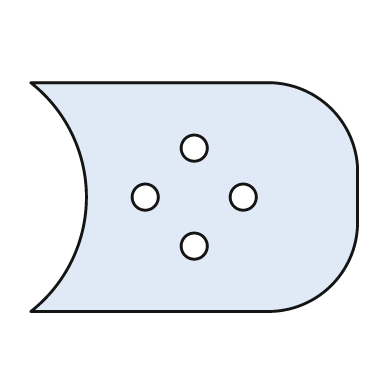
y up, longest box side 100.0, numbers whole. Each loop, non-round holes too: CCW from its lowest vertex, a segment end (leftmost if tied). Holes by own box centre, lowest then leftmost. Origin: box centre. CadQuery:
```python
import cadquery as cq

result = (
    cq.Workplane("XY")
    .moveTo(-50.0, -35.0)
    .lineTo(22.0, -35.0)
    .threePointArc((42.0, -27.0), (50.0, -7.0))
    .lineTo(50.0, 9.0)
    .threePointArc((42.0, 27.0), (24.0, 35.0))
    .lineTo(-50.0, 35.0)
    .threePointArc((-33.0, 0.0), (-50.0, -35.0))
    .close()
    .moveTo(0.0, -15.0)
    .circle(4.0)
    .moveTo(-15.0, 0.0)
    .circle(4.0)
    .moveTo(15.0, 0.0)
    .circle(4.0)
    .moveTo(0.0, 15.0)
    .circle(4.0)
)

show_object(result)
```